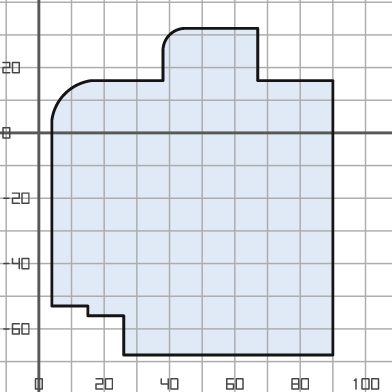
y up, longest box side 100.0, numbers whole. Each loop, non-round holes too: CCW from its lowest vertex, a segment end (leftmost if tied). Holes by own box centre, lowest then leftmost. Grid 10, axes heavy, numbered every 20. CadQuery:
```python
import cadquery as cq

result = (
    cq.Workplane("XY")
    .moveTo(26.0, -68.0)
    .lineTo(90.0, -68.0)
    .lineTo(90.0, 16.0)
    .lineTo(67.0, 16.0)
    .lineTo(67.0, 32.0)
    .lineTo(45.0, 32.0)
    .threePointArc((40.0, 30.0), (38.0, 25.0))
    .lineTo(38.0, 16.0)
    .lineTo(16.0, 16.0)
    .threePointArc((8.0, 12.0), (4.0, 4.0))
    .lineTo(4.0, -53.0)
    .lineTo(15.0, -53.0)
    .lineTo(15.0, -56.0)
    .lineTo(26.0, -56.0)
    .close()
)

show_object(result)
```